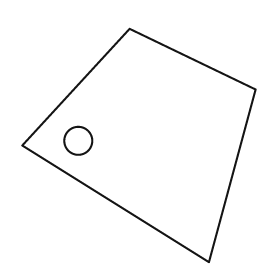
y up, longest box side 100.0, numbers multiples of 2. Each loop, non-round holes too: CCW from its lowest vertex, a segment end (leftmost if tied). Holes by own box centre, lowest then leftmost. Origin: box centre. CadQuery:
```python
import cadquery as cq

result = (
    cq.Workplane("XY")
    .moveTo(30.0, -50.0)
    .lineTo(50.0, 24.0)
    .lineTo(-4.0, 50.0)
    .lineTo(-50.0, 0.0)
    .close()
    .moveTo(-26.0, 2.0)
    .circle(6.0)
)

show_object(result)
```